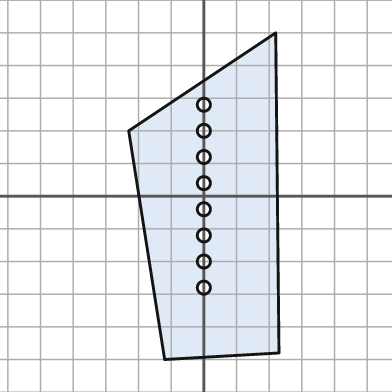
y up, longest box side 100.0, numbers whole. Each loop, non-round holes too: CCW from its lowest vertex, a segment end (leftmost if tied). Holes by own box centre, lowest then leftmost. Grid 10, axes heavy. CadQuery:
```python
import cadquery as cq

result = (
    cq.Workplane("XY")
    .moveTo(-12.0, -50.0)
    .lineTo(23.0, -48.0)
    .lineTo(22.0, 50.0)
    .lineTo(-23.0, 20.0)
    .close()
    .moveTo(0.0, -28.0)
    .circle(2.0)
    .moveTo(0.0, -20.0)
    .circle(2.0)
    .moveTo(0.0, -12.0)
    .circle(2.0)
    .moveTo(0.0, -4.0)
    .circle(2.0)
    .moveTo(0.0, 4.0)
    .circle(2.0)
    .moveTo(0.0, 12.0)
    .circle(2.0)
    .moveTo(0.0, 20.0)
    .circle(2.0)
    .moveTo(0.0, 28.0)
    .circle(2.0)
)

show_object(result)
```